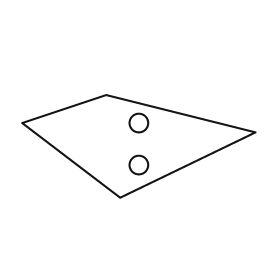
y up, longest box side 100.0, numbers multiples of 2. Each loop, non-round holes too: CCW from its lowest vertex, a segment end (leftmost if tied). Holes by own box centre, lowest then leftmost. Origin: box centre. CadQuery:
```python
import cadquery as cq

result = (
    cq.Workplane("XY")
    .moveTo(-8.0, -22.0)
    .lineTo(50.0, 6.0)
    .lineTo(-14.0, 22.0)
    .lineTo(-50.0, 10.0)
    .close()
    .moveTo(0.0, -8.0)
    .circle(4.0)
    .moveTo(0.0, 10.0)
    .circle(4.0)
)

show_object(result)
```